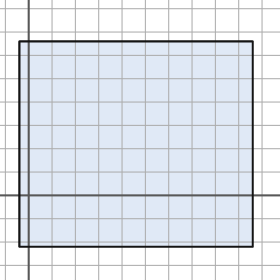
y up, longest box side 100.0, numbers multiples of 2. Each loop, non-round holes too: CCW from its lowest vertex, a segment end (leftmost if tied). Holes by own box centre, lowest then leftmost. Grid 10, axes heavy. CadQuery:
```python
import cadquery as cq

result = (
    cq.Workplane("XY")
    .moveTo(-4.0, -22.0)
    .lineTo(96.0, -22.0)
    .lineTo(96.0, 66.0)
    .lineTo(-4.0, 66.0)
    .close()
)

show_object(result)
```